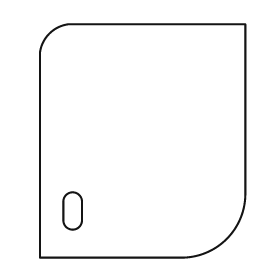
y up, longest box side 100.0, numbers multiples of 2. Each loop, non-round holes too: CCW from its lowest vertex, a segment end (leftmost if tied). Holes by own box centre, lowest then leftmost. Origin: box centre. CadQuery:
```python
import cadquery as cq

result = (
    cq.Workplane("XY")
    .moveTo(-44.0, -50.0)
    .lineTo(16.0, -50.0)
    .threePointArc((36.0, -42.0), (44.0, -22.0))
    .lineTo(44.0, 50.0)
    .lineTo(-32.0, 50.0)
    .threePointArc((-40.0, 46.0), (-44.0, 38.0))
    .close()
    .moveTo(-34.0, -34.0)
    .threePointArc((-30.0, -38.0), (-26.0, -34.0))
    .lineTo(-26.0, -26.0)
    .threePointArc((-30.0, -22.0), (-34.0, -26.0))
    .close()
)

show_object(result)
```